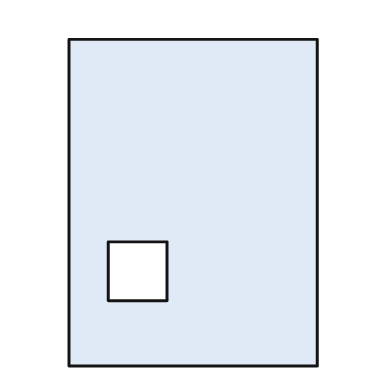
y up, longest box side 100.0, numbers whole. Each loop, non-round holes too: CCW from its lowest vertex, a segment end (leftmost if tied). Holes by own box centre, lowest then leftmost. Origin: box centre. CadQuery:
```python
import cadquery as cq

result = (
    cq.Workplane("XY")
    .moveTo(-38.0, -50.0)
    .lineTo(38.0, -50.0)
    .lineTo(38.0, 50.0)
    .lineTo(-38.0, 50.0)
    .close()
    .moveTo(-26.0, -30.0)
    .lineTo(-8.0, -30.0)
    .lineTo(-8.0, -12.0)
    .lineTo(-26.0, -12.0)
    .close()
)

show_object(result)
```